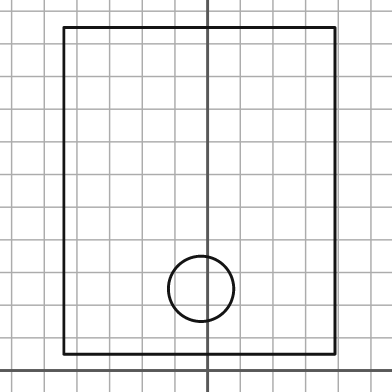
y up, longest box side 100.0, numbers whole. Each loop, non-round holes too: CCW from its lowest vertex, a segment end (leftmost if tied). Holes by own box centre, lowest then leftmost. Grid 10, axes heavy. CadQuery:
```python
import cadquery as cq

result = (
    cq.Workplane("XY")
    .moveTo(-44.0, 5.0)
    .lineTo(39.0, 5.0)
    .lineTo(39.0, 105.0)
    .lineTo(-44.0, 105.0)
    .close()
    .moveTo(-2.0, 25.0)
    .circle(10.0)
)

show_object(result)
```